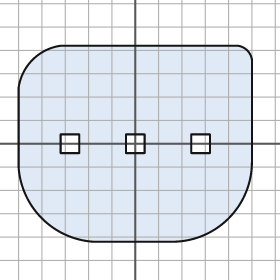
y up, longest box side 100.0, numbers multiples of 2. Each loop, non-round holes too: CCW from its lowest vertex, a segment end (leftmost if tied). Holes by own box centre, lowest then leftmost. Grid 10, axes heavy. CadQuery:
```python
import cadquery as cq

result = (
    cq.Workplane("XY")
    .moveTo(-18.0, -42.0)
    .lineTo(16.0, -42.0)
    .threePointArc((40.0, -32.0), (50.0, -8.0))
    .lineTo(50.0, 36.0)
    .threePointArc((48.0, 40.0), (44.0, 42.0))
    .lineTo(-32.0, 42.0)
    .threePointArc((-44.0, 36.0), (-50.0, 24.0))
    .lineTo(-50.0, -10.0)
    .threePointArc((-40.0, -32.0), (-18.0, -42.0))
    .close()
    .moveTo(-32.0, -4.0)
    .lineTo(-24.0, -4.0)
    .lineTo(-24.0, 4.0)
    .lineTo(-32.0, 4.0)
    .close()
    .moveTo(-4.0, -4.0)
    .lineTo(4.0, -4.0)
    .lineTo(4.0, 4.0)
    .lineTo(-4.0, 4.0)
    .close()
    .moveTo(24.0, -4.0)
    .lineTo(32.0, -4.0)
    .lineTo(32.0, 4.0)
    .lineTo(24.0, 4.0)
    .close()
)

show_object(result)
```